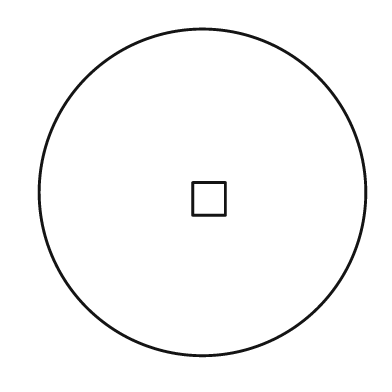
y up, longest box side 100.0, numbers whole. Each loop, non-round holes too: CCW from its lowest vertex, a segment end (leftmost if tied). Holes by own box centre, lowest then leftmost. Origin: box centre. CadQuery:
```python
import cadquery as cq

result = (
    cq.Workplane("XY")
    .moveTo(0.0, 0.0)
    .circle(50.0)
    .moveTo(-3.0, -7.0)
    .lineTo(7.0, -7.0)
    .lineTo(7.0, 3.0)
    .lineTo(-3.0, 3.0)
    .close()
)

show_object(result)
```